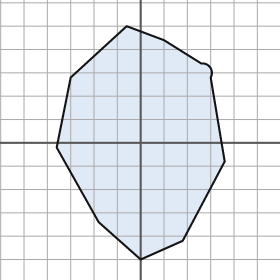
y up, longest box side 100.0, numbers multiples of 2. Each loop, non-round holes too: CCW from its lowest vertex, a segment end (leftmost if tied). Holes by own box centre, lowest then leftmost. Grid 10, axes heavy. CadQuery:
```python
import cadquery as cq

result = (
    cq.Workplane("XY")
    .moveTo(0.0, -50.0)
    .lineTo(18.0, -42.0)
    .lineTo(36.0, -8.0)
    .lineTo(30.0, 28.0)
    .threePointArc((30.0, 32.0), (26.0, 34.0))
    .lineTo(10.0, 44.0)
    .lineTo(-6.0, 50.0)
    .lineTo(-30.0, 28.0)
    .lineTo(-36.0, -2.0)
    .lineTo(-18.0, -34.0)
    .close()
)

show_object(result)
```